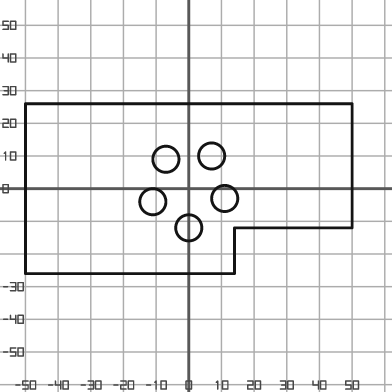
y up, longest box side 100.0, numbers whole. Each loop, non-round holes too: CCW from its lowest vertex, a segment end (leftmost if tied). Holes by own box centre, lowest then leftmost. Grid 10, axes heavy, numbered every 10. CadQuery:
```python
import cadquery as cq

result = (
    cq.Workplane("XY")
    .moveTo(-50.0, -26.0)
    .lineTo(14.0, -26.0)
    .lineTo(14.0, -12.0)
    .lineTo(50.0, -12.0)
    .lineTo(50.0, 26.0)
    .lineTo(-50.0, 26.0)
    .close()
    .moveTo(0.0, -12.0)
    .circle(4.0)
    .moveTo(-11.0, -4.0)
    .circle(4.0)
    .moveTo(11.0, -3.0)
    .circle(4.0)
    .moveTo(-7.0, 9.0)
    .circle(4.0)
    .moveTo(7.0, 10.0)
    .circle(4.0)
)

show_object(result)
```